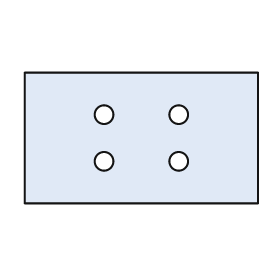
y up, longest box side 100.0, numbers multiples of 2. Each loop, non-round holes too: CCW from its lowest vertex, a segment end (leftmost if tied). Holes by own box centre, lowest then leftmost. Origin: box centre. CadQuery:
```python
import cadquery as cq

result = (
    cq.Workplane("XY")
    .moveTo(-50.0, -28.0)
    .lineTo(50.0, -28.0)
    .lineTo(50.0, 28.0)
    .lineTo(-50.0, 28.0)
    .close()
    .moveTo(-16.0, -10.0)
    .circle(4.0)
    .moveTo(16.0, -10.0)
    .circle(4.0)
    .moveTo(-16.0, 10.0)
    .circle(4.0)
    .moveTo(16.0, 10.0)
    .circle(4.0)
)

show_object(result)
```